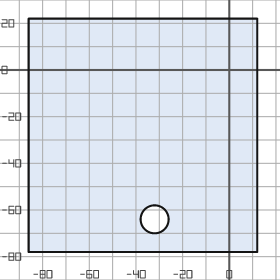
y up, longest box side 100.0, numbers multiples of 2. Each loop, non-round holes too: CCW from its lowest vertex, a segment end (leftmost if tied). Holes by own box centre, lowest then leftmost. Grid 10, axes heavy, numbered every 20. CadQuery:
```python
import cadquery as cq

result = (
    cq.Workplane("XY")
    .moveTo(-86.0, -78.0)
    .lineTo(12.0, -78.0)
    .lineTo(12.0, 22.0)
    .lineTo(-86.0, 22.0)
    .close()
    .moveTo(-32.0, -64.0)
    .circle(6.0)
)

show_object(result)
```